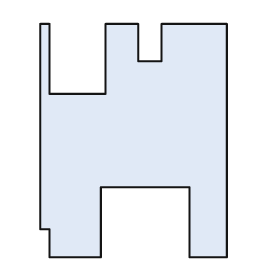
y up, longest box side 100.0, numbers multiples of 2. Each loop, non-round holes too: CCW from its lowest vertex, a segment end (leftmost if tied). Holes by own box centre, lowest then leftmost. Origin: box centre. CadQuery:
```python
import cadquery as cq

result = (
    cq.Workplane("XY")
    .moveTo(-36.0, -50.0)
    .lineTo(-14.0, -50.0)
    .lineTo(-14.0, -20.0)
    .lineTo(24.0, -20.0)
    .lineTo(24.0, -50.0)
    .lineTo(40.0, -50.0)
    .lineTo(40.0, 50.0)
    .lineTo(12.0, 50.0)
    .lineTo(12.0, 34.0)
    .lineTo(2.0, 34.0)
    .lineTo(2.0, 50.0)
    .lineTo(-12.0, 50.0)
    .lineTo(-12.0, 20.0)
    .lineTo(-36.0, 20.0)
    .lineTo(-36.0, 50.0)
    .lineTo(-40.0, 50.0)
    .lineTo(-40.0, -38.0)
    .lineTo(-36.0, -38.0)
    .close()
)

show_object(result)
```